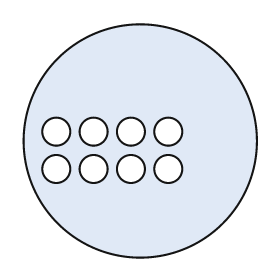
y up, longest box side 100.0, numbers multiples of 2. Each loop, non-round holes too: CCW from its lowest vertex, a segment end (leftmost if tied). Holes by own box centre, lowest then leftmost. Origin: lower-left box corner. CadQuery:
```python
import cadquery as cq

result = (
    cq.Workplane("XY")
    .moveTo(50.0, 50.0)
    .circle(50.0)
    .moveTo(14.0, 38.0)
    .circle(6.0)
    .moveTo(30.0, 38.0)
    .circle(6.0)
    .moveTo(46.0, 38.0)
    .circle(6.0)
    .moveTo(62.0, 38.0)
    .circle(6.0)
    .moveTo(14.0, 54.0)
    .circle(6.0)
    .moveTo(30.0, 54.0)
    .circle(6.0)
    .moveTo(46.0, 54.0)
    .circle(6.0)
    .moveTo(62.0, 54.0)
    .circle(6.0)
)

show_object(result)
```